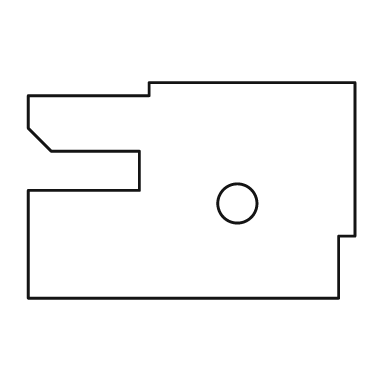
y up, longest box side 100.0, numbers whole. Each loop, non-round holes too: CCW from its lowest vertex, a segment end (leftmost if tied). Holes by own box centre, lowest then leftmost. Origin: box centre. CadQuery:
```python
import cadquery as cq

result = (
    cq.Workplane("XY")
    .moveTo(-50.0, -33.0)
    .lineTo(45.0, -33.0)
    .lineTo(45.0, -14.0)
    .lineTo(50.0, -14.0)
    .lineTo(50.0, 33.0)
    .lineTo(-13.0, 33.0)
    .lineTo(-13.0, 29.0)
    .lineTo(-50.0, 29.0)
    .lineTo(-50.0, 19.0)
    .lineTo(-43.0, 12.0)
    .lineTo(-16.0, 12.0)
    .lineTo(-16.0, 0.0)
    .lineTo(-50.0, 0.0)
    .close()
    .moveTo(14.0, -4.0)
    .circle(6.0)
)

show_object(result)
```